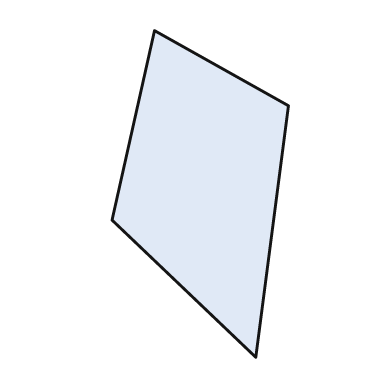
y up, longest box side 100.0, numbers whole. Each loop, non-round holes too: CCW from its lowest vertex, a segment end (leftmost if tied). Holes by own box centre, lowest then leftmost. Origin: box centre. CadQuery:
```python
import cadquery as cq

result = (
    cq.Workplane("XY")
    .moveTo(17.0, -50.0)
    .lineTo(27.0, 27.0)
    .lineTo(-14.0, 50.0)
    .lineTo(-27.0, -8.0)
    .close()
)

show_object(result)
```